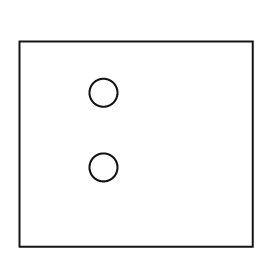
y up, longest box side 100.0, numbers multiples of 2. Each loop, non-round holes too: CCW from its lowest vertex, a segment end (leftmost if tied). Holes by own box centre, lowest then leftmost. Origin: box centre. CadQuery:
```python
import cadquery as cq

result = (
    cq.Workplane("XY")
    .moveTo(-50.0, -44.0)
    .lineTo(50.0, -44.0)
    .lineTo(50.0, 44.0)
    .lineTo(-50.0, 44.0)
    .close()
    .moveTo(-14.0, -10.0)
    .circle(6.0)
    .moveTo(-14.0, 22.0)
    .circle(6.0)
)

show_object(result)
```